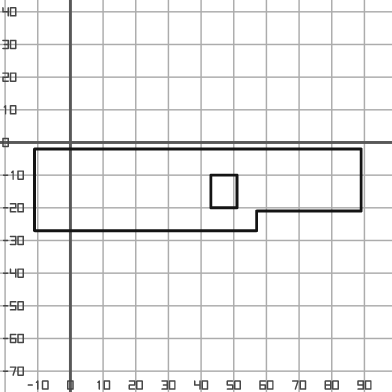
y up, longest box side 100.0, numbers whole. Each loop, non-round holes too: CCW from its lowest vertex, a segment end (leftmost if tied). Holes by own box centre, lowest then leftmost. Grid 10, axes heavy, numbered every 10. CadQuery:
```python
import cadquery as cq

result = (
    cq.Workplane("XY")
    .moveTo(-11.0, -27.0)
    .lineTo(57.0, -27.0)
    .lineTo(57.0, -21.0)
    .lineTo(89.0, -21.0)
    .lineTo(89.0, -2.0)
    .lineTo(-11.0, -2.0)
    .close()
    .moveTo(43.0, -20.0)
    .lineTo(51.0, -20.0)
    .lineTo(51.0, -10.0)
    .lineTo(43.0, -10.0)
    .close()
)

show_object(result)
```